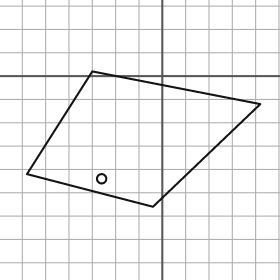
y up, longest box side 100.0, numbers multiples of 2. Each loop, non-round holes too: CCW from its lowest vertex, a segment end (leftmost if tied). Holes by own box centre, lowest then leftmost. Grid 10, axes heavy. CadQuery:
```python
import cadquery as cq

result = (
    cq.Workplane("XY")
    .moveTo(-4.0, -56.0)
    .lineTo(42.0, -12.0)
    .lineTo(-30.0, 2.0)
    .lineTo(-58.0, -42.0)
    .close()
    .moveTo(-26.0, -44.0)
    .circle(2.0)
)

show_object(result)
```